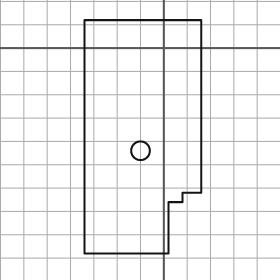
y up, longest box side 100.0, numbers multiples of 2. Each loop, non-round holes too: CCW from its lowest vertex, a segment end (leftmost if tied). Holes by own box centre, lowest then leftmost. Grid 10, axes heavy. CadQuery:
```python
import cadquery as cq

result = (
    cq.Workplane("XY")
    .moveTo(-34.0, -88.0)
    .lineTo(2.0, -88.0)
    .lineTo(2.0, -66.0)
    .lineTo(8.0, -66.0)
    .lineTo(8.0, -62.0)
    .lineTo(16.0, -62.0)
    .lineTo(16.0, 12.0)
    .lineTo(-34.0, 12.0)
    .close()
    .moveTo(-10.0, -44.0)
    .circle(4.0)
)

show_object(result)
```